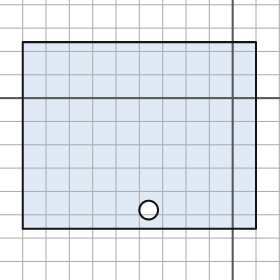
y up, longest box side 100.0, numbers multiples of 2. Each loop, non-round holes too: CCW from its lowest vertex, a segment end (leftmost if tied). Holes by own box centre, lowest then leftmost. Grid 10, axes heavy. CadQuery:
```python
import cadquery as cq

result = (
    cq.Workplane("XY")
    .moveTo(-90.0, -56.0)
    .lineTo(10.0, -56.0)
    .lineTo(10.0, 24.0)
    .lineTo(-90.0, 24.0)
    .close()
    .moveTo(-36.0, -48.0)
    .circle(4.0)
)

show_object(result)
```